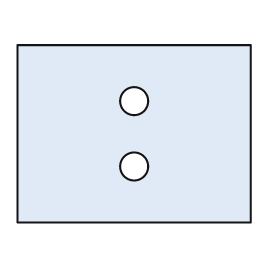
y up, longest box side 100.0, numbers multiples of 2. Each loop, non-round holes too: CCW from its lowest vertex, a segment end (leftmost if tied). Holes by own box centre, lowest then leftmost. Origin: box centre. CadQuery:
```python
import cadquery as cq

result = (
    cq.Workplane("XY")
    .moveTo(-50.0, -38.0)
    .lineTo(50.0, -38.0)
    .lineTo(50.0, 38.0)
    .lineTo(-50.0, 38.0)
    .close()
    .moveTo(0.0, -14.0)
    .circle(6.0)
    .moveTo(0.0, 14.0)
    .circle(6.0)
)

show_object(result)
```